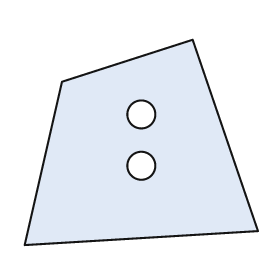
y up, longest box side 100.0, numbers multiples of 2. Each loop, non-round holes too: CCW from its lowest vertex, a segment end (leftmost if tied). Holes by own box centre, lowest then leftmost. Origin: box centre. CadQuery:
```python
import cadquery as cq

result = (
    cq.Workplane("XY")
    .moveTo(-50.0, -44.0)
    .lineTo(50.0, -38.0)
    .lineTo(22.0, 44.0)
    .lineTo(-34.0, 26.0)
    .close()
    .moveTo(0.0, -10.0)
    .circle(6.0)
    .moveTo(0.0, 12.0)
    .circle(6.0)
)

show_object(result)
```